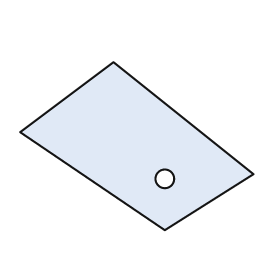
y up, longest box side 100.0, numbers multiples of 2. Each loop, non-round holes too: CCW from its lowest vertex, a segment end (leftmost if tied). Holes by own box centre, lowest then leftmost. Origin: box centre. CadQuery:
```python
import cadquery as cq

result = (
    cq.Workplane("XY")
    .moveTo(12.0, -36.0)
    .lineTo(50.0, -12.0)
    .lineTo(-10.0, 36.0)
    .lineTo(-50.0, 6.0)
    .close()
    .moveTo(12.0, -14.0)
    .circle(4.0)
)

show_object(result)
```